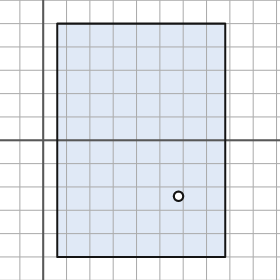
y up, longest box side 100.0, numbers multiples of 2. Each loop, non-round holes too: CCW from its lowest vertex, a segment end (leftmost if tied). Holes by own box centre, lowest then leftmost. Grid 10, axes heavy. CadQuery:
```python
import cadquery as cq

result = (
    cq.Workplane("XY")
    .moveTo(6.0, -50.0)
    .lineTo(78.0, -50.0)
    .lineTo(78.0, 50.0)
    .lineTo(6.0, 50.0)
    .close()
    .moveTo(58.0, -24.0)
    .circle(2.0)
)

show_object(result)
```